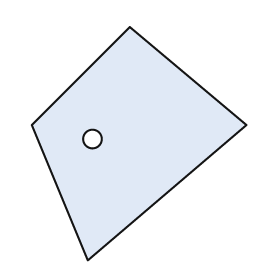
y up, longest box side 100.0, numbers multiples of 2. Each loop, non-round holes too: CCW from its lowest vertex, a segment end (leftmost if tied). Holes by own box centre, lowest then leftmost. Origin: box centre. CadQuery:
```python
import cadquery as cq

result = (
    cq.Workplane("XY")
    .moveTo(-22.0, -50.0)
    .lineTo(46.0, 8.0)
    .lineTo(-4.0, 50.0)
    .lineTo(-46.0, 8.0)
    .close()
    .moveTo(-20.0, 2.0)
    .circle(4.0)
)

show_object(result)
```